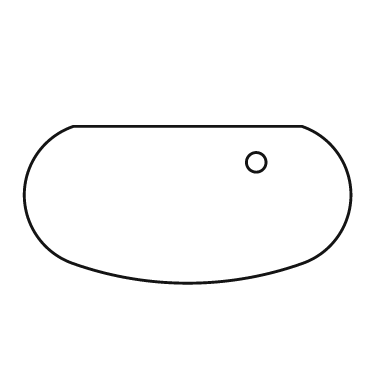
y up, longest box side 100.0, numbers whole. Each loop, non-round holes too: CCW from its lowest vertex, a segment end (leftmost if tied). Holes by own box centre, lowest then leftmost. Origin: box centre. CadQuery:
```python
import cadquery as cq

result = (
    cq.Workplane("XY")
    .moveTo(-35.0, -18.0)
    .threePointArc((0.0, -24.0), (35.0, -18.0))
    .threePointArc((50.0, 3.0), (35.0, 24.0))
    .lineTo(-35.0, 24.0)
    .threePointArc((-50.0, 3.0), (-35.0, -18.0))
    .close()
    .moveTo(21.0, 13.0)
    .circle(3.0)
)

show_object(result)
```